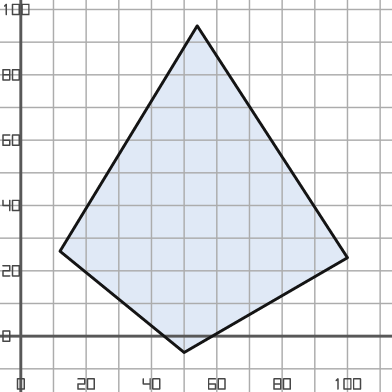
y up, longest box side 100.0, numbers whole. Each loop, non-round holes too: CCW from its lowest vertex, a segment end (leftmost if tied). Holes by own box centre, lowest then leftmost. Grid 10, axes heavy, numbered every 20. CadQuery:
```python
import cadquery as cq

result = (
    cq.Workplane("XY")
    .moveTo(50.0, -5.0)
    .lineTo(100.0, 24.0)
    .lineTo(54.0, 95.0)
    .lineTo(12.0, 26.0)
    .close()
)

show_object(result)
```